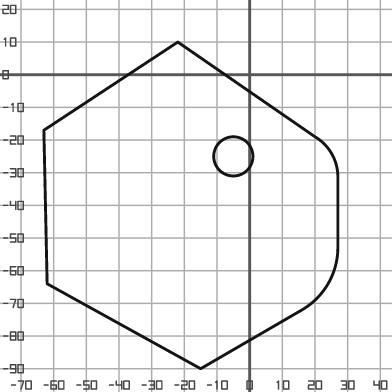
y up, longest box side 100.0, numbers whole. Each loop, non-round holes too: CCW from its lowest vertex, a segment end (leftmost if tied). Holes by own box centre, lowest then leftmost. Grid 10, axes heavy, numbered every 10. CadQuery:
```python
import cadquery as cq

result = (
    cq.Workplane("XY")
    .moveTo(-15.0, -90.0)
    .lineTo(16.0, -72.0)
    .threePointArc((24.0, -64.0), (27.0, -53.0))
    .lineTo(27.0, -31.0)
    .threePointArc((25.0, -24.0), (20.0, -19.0))
    .lineTo(-22.0, 10.0)
    .lineTo(-63.0, -17.0)
    .lineTo(-62.0, -64.0)
    .close()
    .moveTo(-5.0, -25.0)
    .circle(6.0)
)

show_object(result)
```